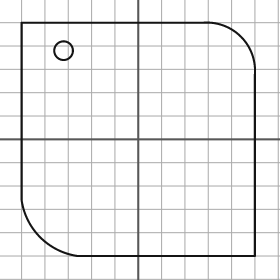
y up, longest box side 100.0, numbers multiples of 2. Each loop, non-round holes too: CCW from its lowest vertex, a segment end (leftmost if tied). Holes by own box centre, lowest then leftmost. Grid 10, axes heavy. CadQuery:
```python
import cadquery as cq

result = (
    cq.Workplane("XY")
    .moveTo(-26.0, -50.0)
    .lineTo(50.0, -50.0)
    .lineTo(50.0, 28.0)
    .threePointArc((44.0, 44.0), (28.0, 50.0))
    .lineTo(-50.0, 50.0)
    .lineTo(-50.0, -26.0)
    .threePointArc((-42.0, -42.0), (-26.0, -50.0))
    .close()
    .moveTo(-32.0, 38.0)
    .circle(4.0)
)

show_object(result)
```